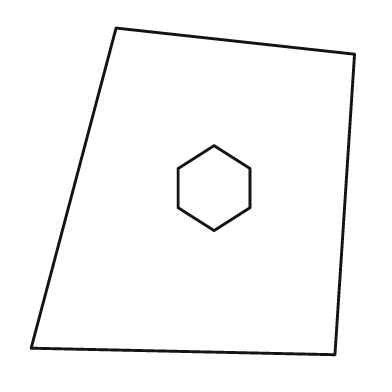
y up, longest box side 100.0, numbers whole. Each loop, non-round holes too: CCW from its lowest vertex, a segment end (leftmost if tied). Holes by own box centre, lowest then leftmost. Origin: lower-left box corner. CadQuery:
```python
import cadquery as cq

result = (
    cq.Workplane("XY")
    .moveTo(93.0, 0.0)
    .lineTo(99.0, 92.0)
    .lineTo(26.0, 100.0)
    .lineTo(0.0, 2.0)
    .close()
    .moveTo(56.0, 38.0)
    .lineTo(67.0, 45.0)
    .lineTo(67.0, 57.0)
    .lineTo(56.0, 64.0)
    .lineTo(45.0, 57.0)
    .lineTo(45.0, 45.0)
    .close()
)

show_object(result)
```